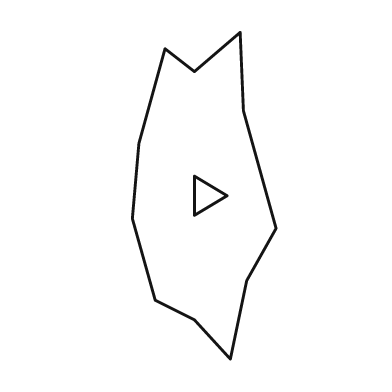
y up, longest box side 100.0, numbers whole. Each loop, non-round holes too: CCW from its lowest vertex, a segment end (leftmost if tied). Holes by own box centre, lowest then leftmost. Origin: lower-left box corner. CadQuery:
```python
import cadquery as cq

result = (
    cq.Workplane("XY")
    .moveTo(30.0, 0.0)
    .lineTo(35.0, 24.0)
    .lineTo(44.0, 40.0)
    .lineTo(34.0, 76.0)
    .lineTo(33.0, 100.0)
    .lineTo(19.0, 88.0)
    .lineTo(10.0, 95.0)
    .lineTo(2.0, 66.0)
    .lineTo(0.0, 43.0)
    .lineTo(7.0, 18.0)
    .lineTo(19.0, 12.0)
    .close()
    .moveTo(19.0, 44.0)
    .lineTo(29.0, 50.0)
    .lineTo(19.0, 56.0)
    .close()
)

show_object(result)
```